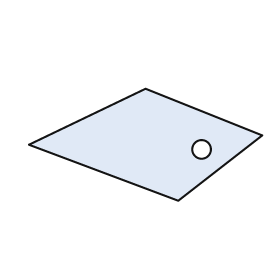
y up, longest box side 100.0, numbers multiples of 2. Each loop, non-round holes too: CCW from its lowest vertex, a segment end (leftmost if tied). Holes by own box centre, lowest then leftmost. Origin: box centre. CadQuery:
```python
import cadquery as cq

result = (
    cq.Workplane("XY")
    .moveTo(14.0, -24.0)
    .lineTo(50.0, 4.0)
    .lineTo(0.0, 24.0)
    .lineTo(-50.0, 0.0)
    .close()
    .moveTo(24.0, -2.0)
    .circle(4.0)
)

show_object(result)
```